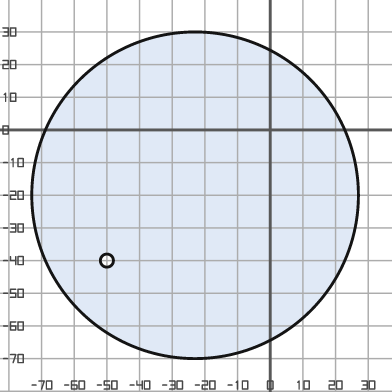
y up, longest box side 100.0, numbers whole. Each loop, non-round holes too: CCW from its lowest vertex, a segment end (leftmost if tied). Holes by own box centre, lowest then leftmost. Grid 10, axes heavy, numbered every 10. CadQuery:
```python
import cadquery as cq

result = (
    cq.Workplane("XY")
    .moveTo(-23.0, -20.0)
    .circle(50.0)
    .moveTo(-50.0, -40.0)
    .circle(2.0)
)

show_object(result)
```